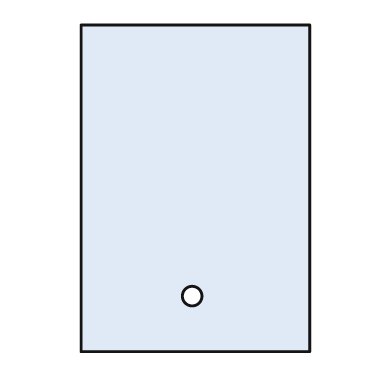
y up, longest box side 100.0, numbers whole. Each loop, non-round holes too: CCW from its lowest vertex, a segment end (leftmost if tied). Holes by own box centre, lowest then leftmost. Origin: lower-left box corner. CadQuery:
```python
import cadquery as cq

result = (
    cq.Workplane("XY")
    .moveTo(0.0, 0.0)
    .lineTo(70.0, 0.0)
    .lineTo(70.0, 100.0)
    .lineTo(0.0, 100.0)
    .close()
    .moveTo(34.0, 17.0)
    .circle(3.0)
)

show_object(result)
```